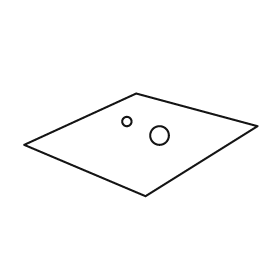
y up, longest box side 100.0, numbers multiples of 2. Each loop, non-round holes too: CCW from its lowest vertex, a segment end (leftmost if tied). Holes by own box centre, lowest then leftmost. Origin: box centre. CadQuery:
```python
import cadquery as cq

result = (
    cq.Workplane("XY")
    .moveTo(2.0, -22.0)
    .lineTo(50.0, 8.0)
    .lineTo(-2.0, 22.0)
    .lineTo(-50.0, 0.0)
    .close()
    .moveTo(8.0, 4.0)
    .circle(4.0)
    .moveTo(-6.0, 10.0)
    .circle(2.0)
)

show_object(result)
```